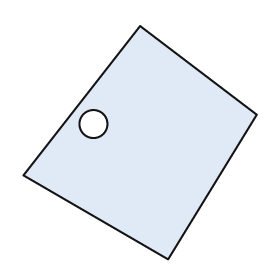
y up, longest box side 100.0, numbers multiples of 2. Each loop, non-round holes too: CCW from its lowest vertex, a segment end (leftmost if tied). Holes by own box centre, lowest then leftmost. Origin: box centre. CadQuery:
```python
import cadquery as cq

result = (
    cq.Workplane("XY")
    .moveTo(12.0, -50.0)
    .lineTo(50.0, 12.0)
    .lineTo(0.0, 50.0)
    .lineTo(-50.0, -14.0)
    .close()
    .moveTo(-20.0, 8.0)
    .circle(6.0)
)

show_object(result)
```